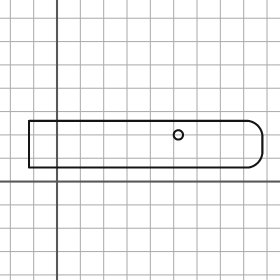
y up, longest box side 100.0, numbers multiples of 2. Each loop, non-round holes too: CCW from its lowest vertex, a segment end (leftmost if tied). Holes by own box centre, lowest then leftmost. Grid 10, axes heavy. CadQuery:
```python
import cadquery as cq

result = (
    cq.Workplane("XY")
    .moveTo(-12.0, 6.0)
    .lineTo(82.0, 6.0)
    .threePointArc((86.0, 8.0), (88.0, 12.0))
    .lineTo(88.0, 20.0)
    .threePointArc((86.0, 24.0), (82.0, 26.0))
    .lineTo(-12.0, 26.0)
    .close()
    .moveTo(52.0, 20.0)
    .circle(2.0)
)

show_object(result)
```